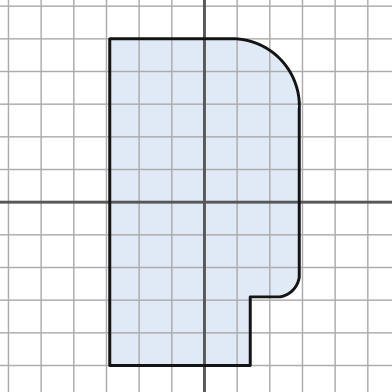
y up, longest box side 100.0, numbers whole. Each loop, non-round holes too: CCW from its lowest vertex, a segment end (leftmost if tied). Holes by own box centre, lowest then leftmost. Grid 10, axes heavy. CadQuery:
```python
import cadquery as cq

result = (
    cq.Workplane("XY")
    .moveTo(-29.0, -50.0)
    .lineTo(14.0, -50.0)
    .lineTo(14.0, -29.0)
    .lineTo(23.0, -29.0)
    .threePointArc((27.0, -27.0), (29.0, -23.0))
    .lineTo(29.0, 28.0)
    .threePointArc((23.0, 44.0), (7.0, 50.0))
    .lineTo(-29.0, 50.0)
    .close()
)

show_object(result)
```